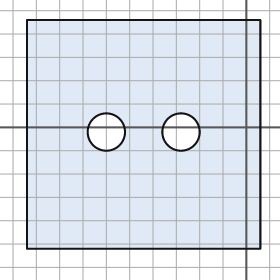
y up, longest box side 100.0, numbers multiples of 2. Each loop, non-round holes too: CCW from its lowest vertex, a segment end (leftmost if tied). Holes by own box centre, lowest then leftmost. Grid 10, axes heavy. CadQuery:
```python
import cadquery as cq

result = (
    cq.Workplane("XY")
    .moveTo(-94.0, -52.0)
    .lineTo(6.0, -52.0)
    .lineTo(6.0, 46.0)
    .lineTo(-94.0, 46.0)
    .close()
    .moveTo(-60.0, -2.0)
    .circle(8.0)
    .moveTo(-28.0, -2.0)
    .circle(8.0)
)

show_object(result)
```